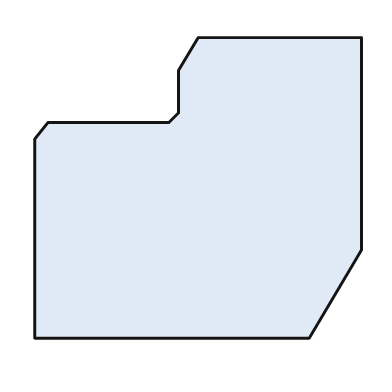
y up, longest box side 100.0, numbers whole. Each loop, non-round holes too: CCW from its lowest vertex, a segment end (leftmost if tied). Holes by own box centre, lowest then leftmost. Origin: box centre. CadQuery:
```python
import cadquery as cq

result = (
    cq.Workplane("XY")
    .moveTo(-50.0, -46.0)
    .lineTo(34.0, -46.0)
    .lineTo(50.0, -19.0)
    .lineTo(50.0, 46.0)
    .lineTo(0.0, 46.0)
    .lineTo(-6.0, 36.0)
    .lineTo(-6.0, 23.0)
    .lineTo(-9.0, 20.0)
    .lineTo(-46.0, 20.0)
    .lineTo(-50.0, 15.0)
    .close()
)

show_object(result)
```